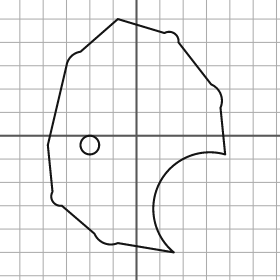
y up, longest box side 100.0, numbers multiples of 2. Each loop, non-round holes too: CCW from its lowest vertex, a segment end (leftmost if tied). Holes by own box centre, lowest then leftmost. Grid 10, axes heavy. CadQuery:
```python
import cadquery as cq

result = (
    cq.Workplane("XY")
    .moveTo(16.0, -50.0)
    .threePointArc((10.0, -20.0), (38.0, -8.0))
    .lineTo(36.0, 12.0)
    .threePointArc((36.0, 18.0), (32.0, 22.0))
    .lineTo(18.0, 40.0)
    .threePointArc((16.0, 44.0), (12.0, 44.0))
    .lineTo(-8.0, 50.0)
    .lineTo(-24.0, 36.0)
    .threePointArc((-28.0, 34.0), (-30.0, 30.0))
    .lineTo(-38.0, -4.0)
    .lineTo(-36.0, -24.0)
    .threePointArc((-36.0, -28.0), (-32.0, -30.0))
    .lineTo(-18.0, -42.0)
    .threePointArc((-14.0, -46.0), (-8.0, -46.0))
    .close()
    .moveTo(-20.0, -4.0)
    .circle(4.0)
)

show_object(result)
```